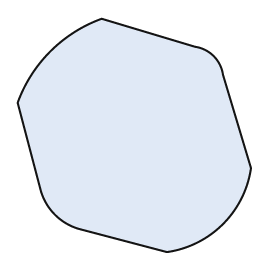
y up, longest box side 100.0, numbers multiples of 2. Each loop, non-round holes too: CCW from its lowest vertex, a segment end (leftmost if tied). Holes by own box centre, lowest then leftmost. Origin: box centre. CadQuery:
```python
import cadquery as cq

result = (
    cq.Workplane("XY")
    .moveTo(14.0, -50.0)
    .threePointArc((38.0, -38.0), (50.0, -14.0))
    .lineTo(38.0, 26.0)
    .threePointArc((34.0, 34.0), (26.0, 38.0))
    .lineTo(-14.0, 50.0)
    .threePointArc((-36.0, 36.0), (-50.0, 14.0))
    .lineTo(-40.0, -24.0)
    .threePointArc((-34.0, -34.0), (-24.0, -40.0))
    .close()
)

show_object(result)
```